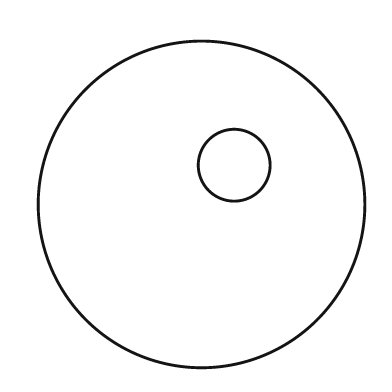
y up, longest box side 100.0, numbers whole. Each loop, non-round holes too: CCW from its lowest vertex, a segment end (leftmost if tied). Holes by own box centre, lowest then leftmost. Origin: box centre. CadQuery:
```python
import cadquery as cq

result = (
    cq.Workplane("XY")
    .moveTo(0.0, 0.0)
    .circle(50.0)
    .moveTo(10.0, 12.0)
    .circle(11.0)
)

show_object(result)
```